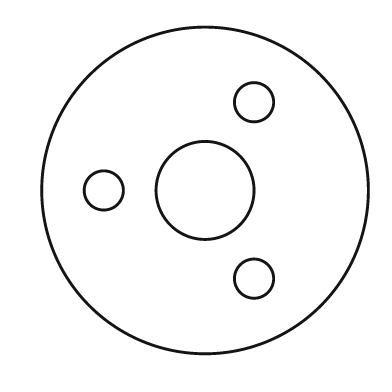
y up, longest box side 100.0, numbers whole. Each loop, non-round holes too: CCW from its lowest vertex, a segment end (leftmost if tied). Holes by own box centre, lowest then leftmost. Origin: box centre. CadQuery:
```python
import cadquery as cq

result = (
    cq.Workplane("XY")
    .moveTo(0.0, 0.0)
    .circle(50.0)
    .moveTo(15.0, -27.0)
    .circle(6.0)
    .moveTo(-31.0, 0.0)
    .circle(6.0)
    .moveTo(0.0, 0.0)
    .circle(15.0)
    .moveTo(15.0, 27.0)
    .circle(6.0)
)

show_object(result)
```